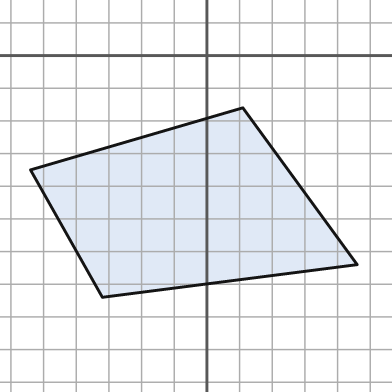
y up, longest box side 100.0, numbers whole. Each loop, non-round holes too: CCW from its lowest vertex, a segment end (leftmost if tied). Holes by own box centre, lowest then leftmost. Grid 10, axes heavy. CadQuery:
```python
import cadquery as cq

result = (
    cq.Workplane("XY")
    .moveTo(-32.0, -74.0)
    .lineTo(46.0, -64.0)
    .lineTo(11.0, -16.0)
    .lineTo(-54.0, -35.0)
    .close()
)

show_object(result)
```